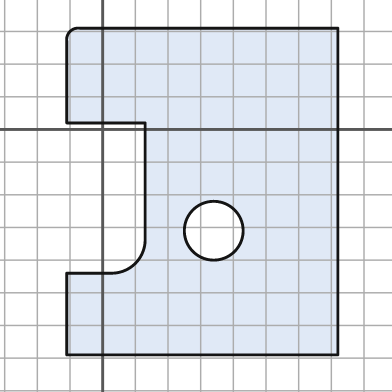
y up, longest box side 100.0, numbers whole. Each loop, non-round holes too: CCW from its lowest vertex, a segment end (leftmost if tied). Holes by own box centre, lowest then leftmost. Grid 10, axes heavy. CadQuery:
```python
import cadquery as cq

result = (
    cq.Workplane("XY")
    .moveTo(-11.0, -69.0)
    .lineTo(72.0, -69.0)
    .lineTo(72.0, 31.0)
    .lineTo(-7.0, 31.0)
    .threePointArc((-10.0, 30.0), (-11.0, 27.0))
    .lineTo(-11.0, 2.0)
    .lineTo(13.0, 2.0)
    .lineTo(13.0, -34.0)
    .threePointArc((10.0, -41.0), (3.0, -44.0))
    .lineTo(-11.0, -44.0)
    .close()
    .moveTo(34.0, -31.0)
    .circle(9.0)
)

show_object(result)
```